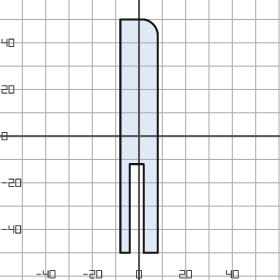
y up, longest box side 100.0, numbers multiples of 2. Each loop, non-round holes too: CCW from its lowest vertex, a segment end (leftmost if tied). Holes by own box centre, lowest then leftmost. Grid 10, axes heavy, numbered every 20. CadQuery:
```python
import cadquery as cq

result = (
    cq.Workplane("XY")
    .moveTo(-8.0, -50.0)
    .lineTo(-4.0, -50.0)
    .lineTo(-4.0, -12.0)
    .lineTo(2.0, -12.0)
    .lineTo(2.0, -50.0)
    .lineTo(8.0, -50.0)
    .lineTo(8.0, 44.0)
    .threePointArc((6.0, 48.0), (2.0, 50.0))
    .lineTo(-8.0, 50.0)
    .close()
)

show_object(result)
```